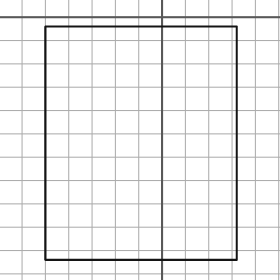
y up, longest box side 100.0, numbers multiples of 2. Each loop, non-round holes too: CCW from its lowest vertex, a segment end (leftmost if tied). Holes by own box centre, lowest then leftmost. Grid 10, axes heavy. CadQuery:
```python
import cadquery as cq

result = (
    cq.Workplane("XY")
    .moveTo(-50.0, -104.0)
    .lineTo(32.0, -104.0)
    .lineTo(32.0, -4.0)
    .lineTo(-50.0, -4.0)
    .close()
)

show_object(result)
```